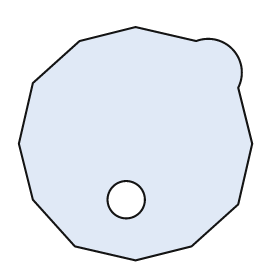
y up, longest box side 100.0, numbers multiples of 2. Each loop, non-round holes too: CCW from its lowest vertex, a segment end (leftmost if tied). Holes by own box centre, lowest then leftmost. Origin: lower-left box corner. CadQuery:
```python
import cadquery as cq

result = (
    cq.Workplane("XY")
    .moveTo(50.0, 0.0)
    .lineTo(74.0, 6.0)
    .lineTo(94.0, 24.0)
    .lineTo(100.0, 50.0)
    .lineTo(94.0, 74.0)
    .threePointArc((92.0, 90.0), (76.0, 94.0))
    .lineTo(50.0, 100.0)
    .lineTo(26.0, 94.0)
    .lineTo(6.0, 76.0)
    .lineTo(0.0, 50.0)
    .lineTo(6.0, 26.0)
    .lineTo(24.0, 6.0)
    .close()
    .moveTo(46.0, 26.0)
    .circle(8.0)
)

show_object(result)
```